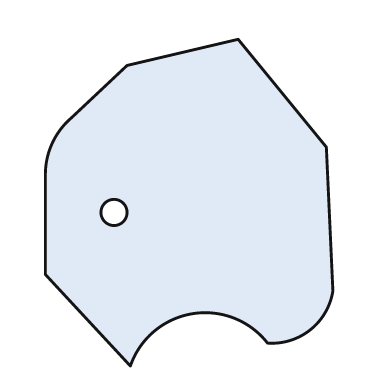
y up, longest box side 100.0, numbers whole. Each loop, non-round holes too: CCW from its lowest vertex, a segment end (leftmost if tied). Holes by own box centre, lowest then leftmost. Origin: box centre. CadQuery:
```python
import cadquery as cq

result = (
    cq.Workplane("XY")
    .moveTo(-18.0, -50.0)
    .threePointArc((1.0, -34.0), (24.0, -43.0))
    .threePointArc((37.0, -39.0), (44.0, -27.0))
    .lineTo(42.0, 17.0)
    .lineTo(15.0, 50.0)
    .lineTo(-19.0, 42.0)
    .lineTo(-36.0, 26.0)
    .threePointArc((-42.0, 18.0), (-44.0, 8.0))
    .lineTo(-44.0, -22.0)
    .close()
    .moveTo(-23.0, -3.0)
    .circle(4.0)
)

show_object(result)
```